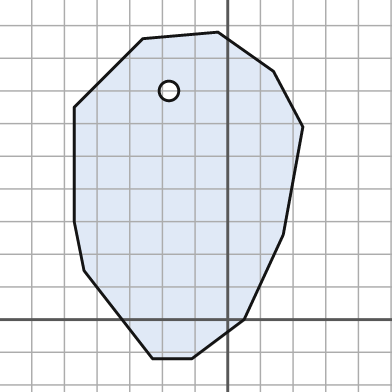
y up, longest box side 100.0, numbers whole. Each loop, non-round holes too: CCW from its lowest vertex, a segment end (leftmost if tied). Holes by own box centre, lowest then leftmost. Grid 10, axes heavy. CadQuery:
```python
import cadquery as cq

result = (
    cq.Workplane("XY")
    .moveTo(-23.0, -12.0)
    .lineTo(-11.0, -12.0)
    .lineTo(5.0, 0.0)
    .lineTo(17.0, 26.0)
    .lineTo(23.0, 59.0)
    .lineTo(14.0, 76.0)
    .lineTo(-3.0, 88.0)
    .lineTo(-26.0, 86.0)
    .lineTo(-47.0, 65.0)
    .lineTo(-47.0, 30.0)
    .lineTo(-44.0, 15.0)
    .close()
    .moveTo(-18.0, 70.0)
    .circle(3.0)
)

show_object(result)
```